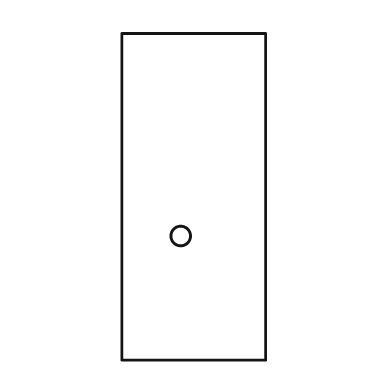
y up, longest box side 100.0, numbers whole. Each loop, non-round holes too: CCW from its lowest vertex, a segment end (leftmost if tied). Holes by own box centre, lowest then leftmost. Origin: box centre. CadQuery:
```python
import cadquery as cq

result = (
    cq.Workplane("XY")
    .moveTo(-22.0, -50.0)
    .lineTo(22.0, -50.0)
    .lineTo(22.0, 50.0)
    .lineTo(-22.0, 50.0)
    .close()
    .moveTo(-4.0, -12.0)
    .circle(3.0)
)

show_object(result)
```